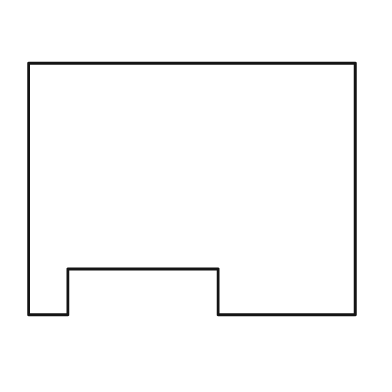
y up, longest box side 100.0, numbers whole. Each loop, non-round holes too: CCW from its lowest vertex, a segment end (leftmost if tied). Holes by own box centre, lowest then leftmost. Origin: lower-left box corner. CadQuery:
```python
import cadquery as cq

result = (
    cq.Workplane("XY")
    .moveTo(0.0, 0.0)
    .lineTo(12.0, 0.0)
    .lineTo(12.0, 14.0)
    .lineTo(58.0, 14.0)
    .lineTo(58.0, 0.0)
    .lineTo(100.0, 0.0)
    .lineTo(100.0, 77.0)
    .lineTo(0.0, 77.0)
    .close()
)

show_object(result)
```